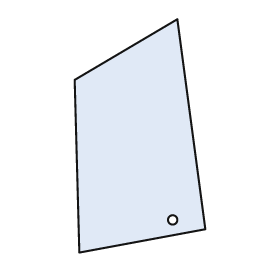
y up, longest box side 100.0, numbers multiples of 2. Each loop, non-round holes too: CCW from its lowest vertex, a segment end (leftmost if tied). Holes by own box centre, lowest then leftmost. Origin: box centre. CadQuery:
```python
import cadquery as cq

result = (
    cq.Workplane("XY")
    .moveTo(-26.0, -50.0)
    .lineTo(28.0, -40.0)
    .lineTo(16.0, 50.0)
    .lineTo(-28.0, 24.0)
    .close()
    .moveTo(14.0, -36.0)
    .circle(2.0)
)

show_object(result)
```